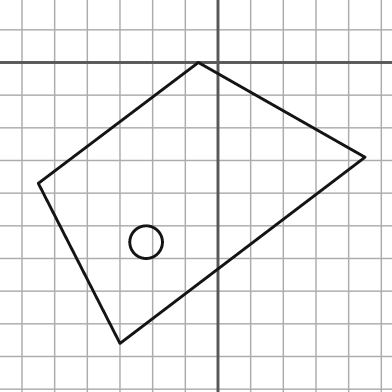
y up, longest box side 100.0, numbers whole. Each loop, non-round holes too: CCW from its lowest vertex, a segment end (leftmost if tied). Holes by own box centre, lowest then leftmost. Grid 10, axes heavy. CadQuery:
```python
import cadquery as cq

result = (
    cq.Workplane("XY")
    .moveTo(-30.0, -86.0)
    .lineTo(45.0, -29.0)
    .lineTo(-6.0, 0.0)
    .lineTo(-55.0, -37.0)
    .close()
    .moveTo(-22.0, -55.0)
    .circle(5.0)
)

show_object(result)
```